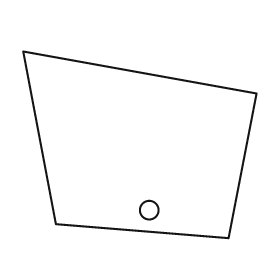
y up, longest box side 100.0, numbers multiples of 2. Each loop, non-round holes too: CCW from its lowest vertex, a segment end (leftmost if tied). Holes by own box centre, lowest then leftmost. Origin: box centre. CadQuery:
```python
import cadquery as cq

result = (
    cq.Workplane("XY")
    .moveTo(38.0, -40.0)
    .lineTo(50.0, 22.0)
    .lineTo(-50.0, 40.0)
    .lineTo(-36.0, -34.0)
    .close()
    .moveTo(4.0, -28.0)
    .circle(4.0)
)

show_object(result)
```